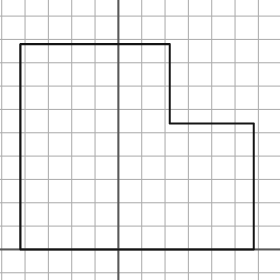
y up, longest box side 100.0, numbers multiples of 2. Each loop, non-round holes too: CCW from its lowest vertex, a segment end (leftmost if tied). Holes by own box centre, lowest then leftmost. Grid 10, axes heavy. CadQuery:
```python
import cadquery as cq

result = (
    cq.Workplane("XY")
    .moveTo(-42.0, 0.0)
    .lineTo(58.0, 0.0)
    .lineTo(58.0, 54.0)
    .lineTo(22.0, 54.0)
    .lineTo(22.0, 88.0)
    .lineTo(-42.0, 88.0)
    .close()
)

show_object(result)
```